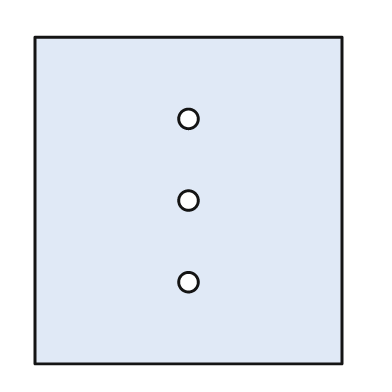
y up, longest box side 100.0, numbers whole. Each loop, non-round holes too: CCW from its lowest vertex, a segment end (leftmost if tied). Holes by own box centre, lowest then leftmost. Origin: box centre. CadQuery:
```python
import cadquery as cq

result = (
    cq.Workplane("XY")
    .moveTo(-47.0, -50.0)
    .lineTo(47.0, -50.0)
    .lineTo(47.0, 50.0)
    .lineTo(-47.0, 50.0)
    .close()
    .moveTo(0.0, -25.0)
    .circle(3.0)
    .moveTo(0.0, 0.0)
    .circle(3.0)
    .moveTo(0.0, 25.0)
    .circle(3.0)
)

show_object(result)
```